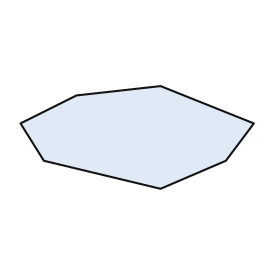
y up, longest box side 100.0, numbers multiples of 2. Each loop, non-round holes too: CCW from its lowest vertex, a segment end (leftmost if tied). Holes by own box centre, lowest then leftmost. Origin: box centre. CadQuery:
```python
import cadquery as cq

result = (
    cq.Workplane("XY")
    .moveTo(10.0, -22.0)
    .lineTo(38.0, -10.0)
    .lineTo(50.0, 6.0)
    .lineTo(10.0, 22.0)
    .lineTo(-26.0, 18.0)
    .lineTo(-50.0, 6.0)
    .lineTo(-40.0, -10.0)
    .close()
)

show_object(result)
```